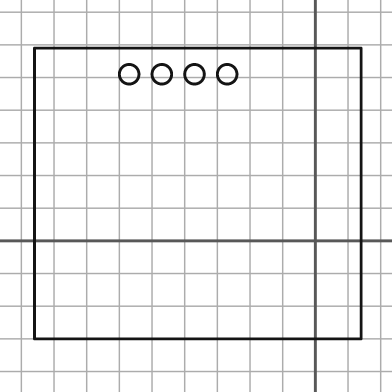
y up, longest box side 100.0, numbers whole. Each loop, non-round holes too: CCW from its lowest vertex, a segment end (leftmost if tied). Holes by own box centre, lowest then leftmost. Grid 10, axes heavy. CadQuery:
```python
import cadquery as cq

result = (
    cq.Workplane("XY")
    .moveTo(-86.0, -30.0)
    .lineTo(14.0, -30.0)
    .lineTo(14.0, 59.0)
    .lineTo(-86.0, 59.0)
    .close()
    .moveTo(-57.0, 51.0)
    .circle(3.0)
    .moveTo(-47.0, 51.0)
    .circle(3.0)
    .moveTo(-37.0, 51.0)
    .circle(3.0)
    .moveTo(-27.0, 51.0)
    .circle(3.0)
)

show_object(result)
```